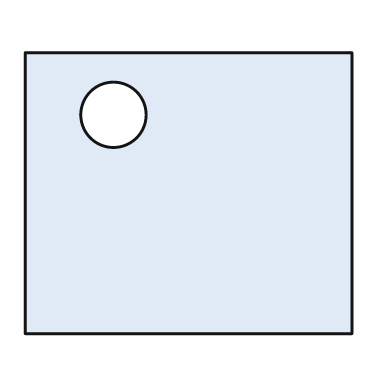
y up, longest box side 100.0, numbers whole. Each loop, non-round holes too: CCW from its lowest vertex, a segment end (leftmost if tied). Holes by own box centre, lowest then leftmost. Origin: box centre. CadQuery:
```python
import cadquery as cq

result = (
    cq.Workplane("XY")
    .moveTo(-50.0, -43.0)
    .lineTo(50.0, -43.0)
    .lineTo(50.0, 43.0)
    .lineTo(-50.0, 43.0)
    .close()
    .moveTo(-23.0, 24.0)
    .circle(10.0)
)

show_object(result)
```